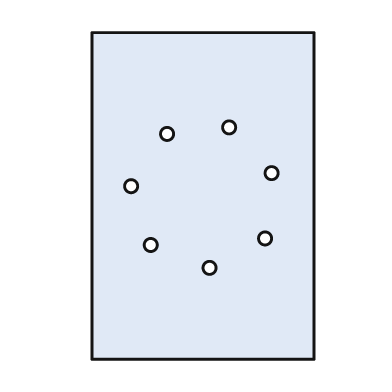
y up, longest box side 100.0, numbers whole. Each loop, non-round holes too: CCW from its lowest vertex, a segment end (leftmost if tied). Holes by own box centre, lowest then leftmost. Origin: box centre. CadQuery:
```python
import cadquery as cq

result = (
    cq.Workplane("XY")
    .moveTo(-34.0, -50.0)
    .lineTo(34.0, -50.0)
    .lineTo(34.0, 50.0)
    .lineTo(-34.0, 50.0)
    .close()
    .moveTo(2.0, -22.0)
    .circle(2.0)
    .moveTo(-16.0, -15.0)
    .circle(2.0)
    .moveTo(19.0, -13.0)
    .circle(2.0)
    .moveTo(-22.0, 3.0)
    .circle(2.0)
    .moveTo(21.0, 7.0)
    .circle(2.0)
    .moveTo(-11.0, 19.0)
    .circle(2.0)
    .moveTo(8.0, 21.0)
    .circle(2.0)
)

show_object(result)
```